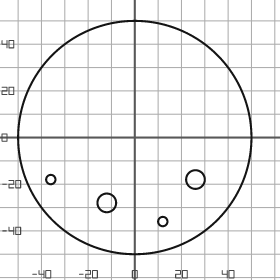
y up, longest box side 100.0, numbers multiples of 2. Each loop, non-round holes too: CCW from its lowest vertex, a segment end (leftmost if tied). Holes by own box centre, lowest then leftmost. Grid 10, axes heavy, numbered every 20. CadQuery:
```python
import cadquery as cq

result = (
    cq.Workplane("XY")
    .moveTo(0.0, 0.0)
    .circle(50.0)
    .moveTo(12.0, -36.0)
    .circle(2.0)
    .moveTo(-12.0, -28.0)
    .circle(4.0)
    .moveTo(-36.0, -18.0)
    .circle(2.0)
    .moveTo(26.0, -18.0)
    .circle(4.0)
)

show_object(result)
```